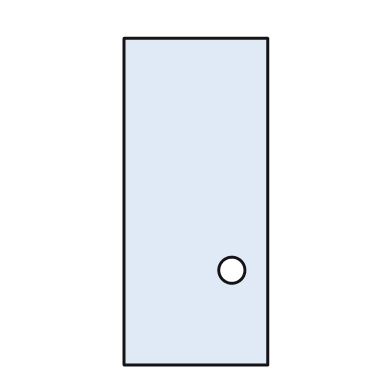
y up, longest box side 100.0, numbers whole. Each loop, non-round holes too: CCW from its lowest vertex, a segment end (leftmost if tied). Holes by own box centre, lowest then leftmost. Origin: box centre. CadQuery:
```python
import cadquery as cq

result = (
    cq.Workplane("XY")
    .moveTo(-22.0, -50.0)
    .lineTo(22.0, -50.0)
    .lineTo(22.0, 50.0)
    .lineTo(-22.0, 50.0)
    .close()
    .moveTo(11.0, -21.0)
    .circle(4.0)
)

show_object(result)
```